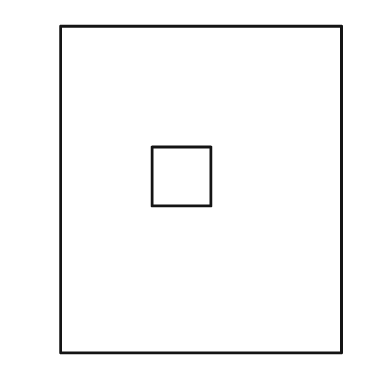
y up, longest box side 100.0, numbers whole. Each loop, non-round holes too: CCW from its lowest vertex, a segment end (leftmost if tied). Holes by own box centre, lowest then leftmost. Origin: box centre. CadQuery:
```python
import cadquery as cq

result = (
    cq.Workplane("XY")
    .moveTo(-43.0, -50.0)
    .lineTo(43.0, -50.0)
    .lineTo(43.0, 50.0)
    .lineTo(-43.0, 50.0)
    .close()
    .moveTo(-15.0, -5.0)
    .lineTo(3.0, -5.0)
    .lineTo(3.0, 13.0)
    .lineTo(-15.0, 13.0)
    .close()
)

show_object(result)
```